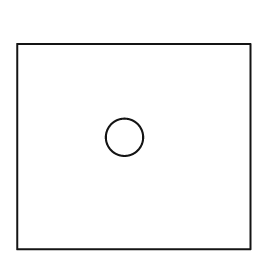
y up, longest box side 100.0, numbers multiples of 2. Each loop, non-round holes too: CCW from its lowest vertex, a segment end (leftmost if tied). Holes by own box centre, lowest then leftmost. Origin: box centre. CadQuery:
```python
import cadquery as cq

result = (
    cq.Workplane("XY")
    .moveTo(-50.0, -44.0)
    .lineTo(50.0, -44.0)
    .lineTo(50.0, 44.0)
    .lineTo(-50.0, 44.0)
    .close()
    .moveTo(-4.0, 4.0)
    .circle(8.0)
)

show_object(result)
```